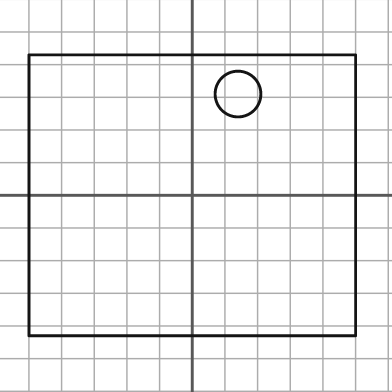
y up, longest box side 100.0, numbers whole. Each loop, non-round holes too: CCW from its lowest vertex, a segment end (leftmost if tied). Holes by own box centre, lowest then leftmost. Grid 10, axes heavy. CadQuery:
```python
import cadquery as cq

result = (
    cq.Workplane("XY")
    .moveTo(-50.0, -43.0)
    .lineTo(50.0, -43.0)
    .lineTo(50.0, 43.0)
    .lineTo(-50.0, 43.0)
    .close()
    .moveTo(14.0, 31.0)
    .circle(7.0)
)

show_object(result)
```